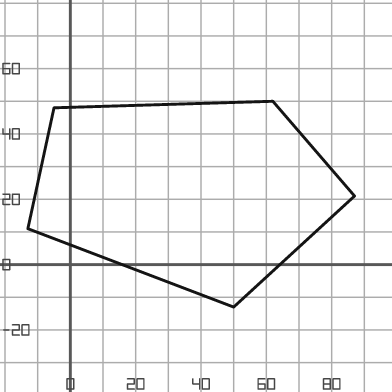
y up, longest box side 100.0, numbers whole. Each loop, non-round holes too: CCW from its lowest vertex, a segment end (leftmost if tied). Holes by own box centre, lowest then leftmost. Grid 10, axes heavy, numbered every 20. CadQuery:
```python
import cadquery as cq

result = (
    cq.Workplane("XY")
    .moveTo(50.0, -13.0)
    .lineTo(87.0, 21.0)
    .lineTo(62.0, 50.0)
    .lineTo(-5.0, 48.0)
    .lineTo(-13.0, 11.0)
    .close()
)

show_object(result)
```